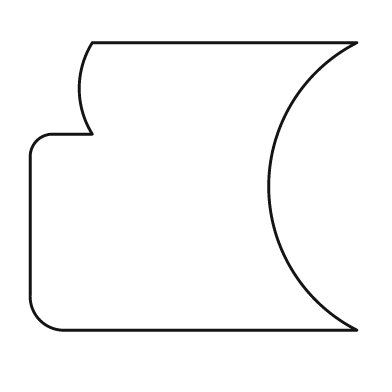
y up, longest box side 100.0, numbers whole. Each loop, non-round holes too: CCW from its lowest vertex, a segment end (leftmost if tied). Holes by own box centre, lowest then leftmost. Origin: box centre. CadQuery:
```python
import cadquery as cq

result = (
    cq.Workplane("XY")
    .moveTo(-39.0, -44.0)
    .lineTo(50.0, -44.0)
    .threePointArc((23.0, 0.0), (50.0, 44.0))
    .lineTo(-31.0, 44.0)
    .threePointArc((-35.0, 30.0), (-31.0, 16.0))
    .lineTo(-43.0, 16.0)
    .threePointArc((-48.0, 14.0), (-50.0, 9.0))
    .lineTo(-50.0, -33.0)
    .threePointArc((-47.0, -41.0), (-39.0, -44.0))
    .close()
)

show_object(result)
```